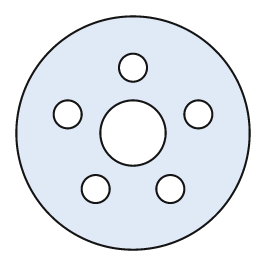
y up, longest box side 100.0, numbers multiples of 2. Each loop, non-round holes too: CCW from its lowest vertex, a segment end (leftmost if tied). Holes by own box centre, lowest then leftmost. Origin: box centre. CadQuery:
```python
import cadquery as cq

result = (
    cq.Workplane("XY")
    .moveTo(0.0, 0.0)
    .circle(50.0)
    .moveTo(-16.0, -24.0)
    .circle(6.0)
    .moveTo(16.0, -24.0)
    .circle(6.0)
    .moveTo(0.0, 0.0)
    .circle(14.0)
    .moveTo(-28.0, 8.0)
    .circle(6.0)
    .moveTo(28.0, 8.0)
    .circle(6.0)
    .moveTo(0.0, 28.0)
    .circle(6.0)
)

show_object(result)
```